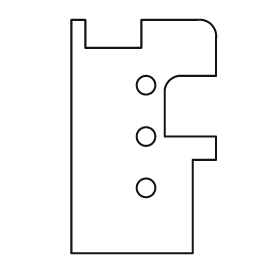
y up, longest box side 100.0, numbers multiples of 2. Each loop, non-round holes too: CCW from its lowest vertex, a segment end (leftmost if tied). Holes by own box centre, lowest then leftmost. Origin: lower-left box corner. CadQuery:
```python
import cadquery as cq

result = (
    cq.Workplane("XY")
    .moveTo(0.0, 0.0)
    .lineTo(52.0, 0.0)
    .lineTo(52.0, 40.0)
    .lineTo(62.0, 40.0)
    .lineTo(62.0, 50.0)
    .lineTo(40.0, 50.0)
    .lineTo(40.0, 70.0)
    .threePointArc((42.0, 74.0), (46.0, 76.0))
    .lineTo(62.0, 76.0)
    .lineTo(62.0, 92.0)
    .threePointArc((60.0, 98.0), (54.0, 100.0))
    .lineTo(30.0, 100.0)
    .lineTo(30.0, 88.0)
    .lineTo(6.0, 88.0)
    .lineTo(6.0, 100.0)
    .lineTo(0.0, 100.0)
    .close()
    .moveTo(32.0, 28.0)
    .circle(4.0)
    .moveTo(32.0, 50.0)
    .circle(4.0)
    .moveTo(32.0, 72.0)
    .circle(4.0)
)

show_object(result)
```